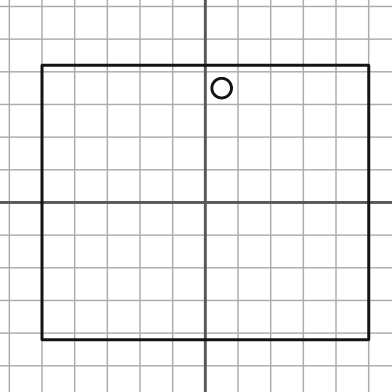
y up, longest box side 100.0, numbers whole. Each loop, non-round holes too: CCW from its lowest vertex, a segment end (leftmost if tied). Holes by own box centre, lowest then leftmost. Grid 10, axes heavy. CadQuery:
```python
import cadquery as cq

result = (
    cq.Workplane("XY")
    .moveTo(-50.0, -42.0)
    .lineTo(50.0, -42.0)
    .lineTo(50.0, 42.0)
    .lineTo(-50.0, 42.0)
    .close()
    .moveTo(5.0, 35.0)
    .circle(3.0)
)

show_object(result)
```